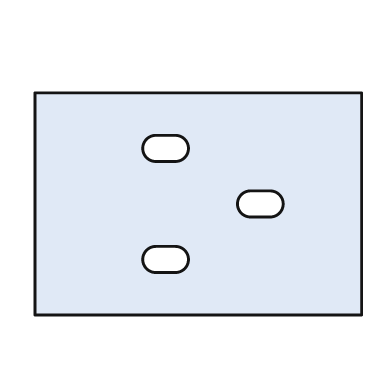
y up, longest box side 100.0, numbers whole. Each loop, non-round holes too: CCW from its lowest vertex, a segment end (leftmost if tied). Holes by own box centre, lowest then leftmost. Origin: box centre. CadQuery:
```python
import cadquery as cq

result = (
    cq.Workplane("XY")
    .moveTo(-50.0, -34.0)
    .lineTo(50.0, -34.0)
    .lineTo(50.0, 34.0)
    .lineTo(-50.0, 34.0)
    .close()
    .moveTo(-13.0, -21.0)
    .lineTo(-7.0, -21.0)
    .threePointArc((-3.0, -17.0), (-7.0, -13.0))
    .lineTo(-13.0, -13.0)
    .threePointArc((-17.0, -17.0), (-13.0, -21.0))
    .close()
    .moveTo(16.0, -4.0)
    .lineTo(22.0, -4.0)
    .threePointArc((26.0, 0.0), (22.0, 4.0))
    .lineTo(16.0, 4.0)
    .threePointArc((12.0, 0.0), (16.0, -4.0))
    .close()
    .moveTo(-13.0, 13.0)
    .lineTo(-7.0, 13.0)
    .threePointArc((-3.0, 17.0), (-7.0, 21.0))
    .lineTo(-13.0, 21.0)
    .threePointArc((-17.0, 17.0), (-13.0, 13.0))
    .close()
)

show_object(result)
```